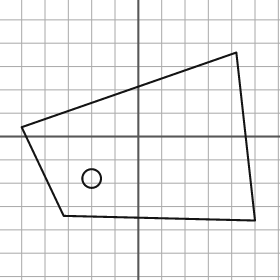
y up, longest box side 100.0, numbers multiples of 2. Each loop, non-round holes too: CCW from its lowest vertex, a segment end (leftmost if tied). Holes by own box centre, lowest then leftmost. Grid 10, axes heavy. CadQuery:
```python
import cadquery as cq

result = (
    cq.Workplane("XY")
    .moveTo(50.0, -36.0)
    .lineTo(42.0, 36.0)
    .lineTo(-50.0, 4.0)
    .lineTo(-32.0, -34.0)
    .close()
    .moveTo(-20.0, -18.0)
    .circle(4.0)
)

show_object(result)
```